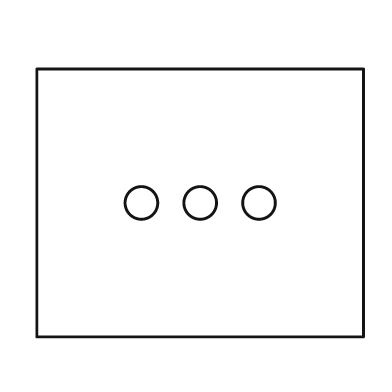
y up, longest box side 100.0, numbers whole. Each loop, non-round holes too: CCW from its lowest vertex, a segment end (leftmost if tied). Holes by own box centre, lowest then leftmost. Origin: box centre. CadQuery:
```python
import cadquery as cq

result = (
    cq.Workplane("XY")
    .moveTo(-50.0, -41.0)
    .lineTo(50.0, -41.0)
    .lineTo(50.0, 41.0)
    .lineTo(-50.0, 41.0)
    .close()
    .moveTo(-18.0, 0.0)
    .circle(5.0)
    .moveTo(0.0, 0.0)
    .circle(5.0)
    .moveTo(18.0, 0.0)
    .circle(5.0)
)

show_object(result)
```